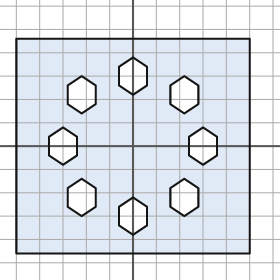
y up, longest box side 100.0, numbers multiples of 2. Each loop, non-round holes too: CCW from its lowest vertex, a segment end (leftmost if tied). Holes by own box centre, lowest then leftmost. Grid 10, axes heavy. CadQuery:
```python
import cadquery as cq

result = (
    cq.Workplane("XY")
    .moveTo(-50.0, -46.0)
    .lineTo(50.0, -46.0)
    .lineTo(50.0, 46.0)
    .lineTo(-50.0, 46.0)
    .close()
    .moveTo(0.0, -38.0)
    .lineTo(6.0, -34.0)
    .lineTo(6.0, -26.0)
    .lineTo(0.0, -22.0)
    .lineTo(-6.0, -26.0)
    .lineTo(-6.0, -34.0)
    .close()
    .moveTo(-22.0, -30.0)
    .lineTo(-16.0, -26.0)
    .lineTo(-16.0, -18.0)
    .lineTo(-22.0, -14.0)
    .lineTo(-28.0, -18.0)
    .lineTo(-28.0, -26.0)
    .close()
    .moveTo(22.0, -30.0)
    .lineTo(28.0, -26.0)
    .lineTo(28.0, -18.0)
    .lineTo(22.0, -14.0)
    .lineTo(16.0, -18.0)
    .lineTo(16.0, -26.0)
    .close()
    .moveTo(-30.0, -8.0)
    .lineTo(-24.0, -4.0)
    .lineTo(-24.0, 4.0)
    .lineTo(-30.0, 8.0)
    .lineTo(-36.0, 4.0)
    .lineTo(-36.0, -4.0)
    .close()
    .moveTo(30.0, -8.0)
    .lineTo(36.0, -4.0)
    .lineTo(36.0, 4.0)
    .lineTo(30.0, 8.0)
    .lineTo(24.0, 4.0)
    .lineTo(24.0, -4.0)
    .close()
    .moveTo(-22.0, 14.0)
    .lineTo(-16.0, 18.0)
    .lineTo(-16.0, 26.0)
    .lineTo(-22.0, 30.0)
    .lineTo(-28.0, 26.0)
    .lineTo(-28.0, 18.0)
    .close()
    .moveTo(22.0, 14.0)
    .lineTo(28.0, 18.0)
    .lineTo(28.0, 26.0)
    .lineTo(22.0, 30.0)
    .lineTo(16.0, 26.0)
    .lineTo(16.0, 18.0)
    .close()
    .moveTo(0.0, 22.0)
    .lineTo(6.0, 26.0)
    .lineTo(6.0, 34.0)
    .lineTo(0.0, 38.0)
    .lineTo(-6.0, 34.0)
    .lineTo(-6.0, 26.0)
    .close()
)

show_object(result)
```